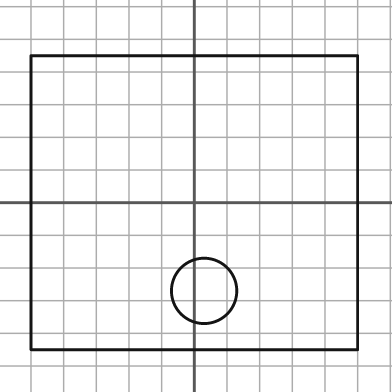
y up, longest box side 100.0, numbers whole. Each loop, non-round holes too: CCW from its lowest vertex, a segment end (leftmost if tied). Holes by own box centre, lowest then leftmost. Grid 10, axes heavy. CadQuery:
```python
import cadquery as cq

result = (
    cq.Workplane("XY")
    .moveTo(-50.0, -45.0)
    .lineTo(50.0, -45.0)
    .lineTo(50.0, 45.0)
    .lineTo(-50.0, 45.0)
    .close()
    .moveTo(3.0, -27.0)
    .circle(10.0)
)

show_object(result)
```